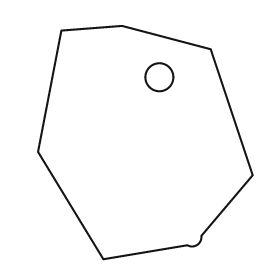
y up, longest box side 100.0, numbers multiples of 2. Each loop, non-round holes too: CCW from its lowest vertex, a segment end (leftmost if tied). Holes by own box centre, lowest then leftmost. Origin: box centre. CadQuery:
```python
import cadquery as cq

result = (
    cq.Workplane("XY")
    .moveTo(-18.0, -50.0)
    .lineTo(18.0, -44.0)
    .threePointArc((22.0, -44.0), (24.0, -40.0))
    .lineTo(46.0, -14.0)
    .lineTo(28.0, 40.0)
    .lineTo(-10.0, 50.0)
    .lineTo(-36.0, 48.0)
    .lineTo(-46.0, -4.0)
    .close()
    .moveTo(6.0, 28.0)
    .circle(6.0)
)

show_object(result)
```